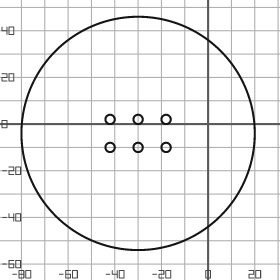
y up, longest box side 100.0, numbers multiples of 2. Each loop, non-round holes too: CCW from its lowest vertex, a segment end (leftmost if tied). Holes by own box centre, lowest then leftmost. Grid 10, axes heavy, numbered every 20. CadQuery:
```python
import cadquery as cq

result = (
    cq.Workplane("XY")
    .moveTo(-30.0, -4.0)
    .circle(50.0)
    .moveTo(-42.0, -10.0)
    .circle(2.0)
    .moveTo(-30.0, -10.0)
    .circle(2.0)
    .moveTo(-18.0, -10.0)
    .circle(2.0)
    .moveTo(-42.0, 2.0)
    .circle(2.0)
    .moveTo(-30.0, 2.0)
    .circle(2.0)
    .moveTo(-18.0, 2.0)
    .circle(2.0)
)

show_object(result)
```